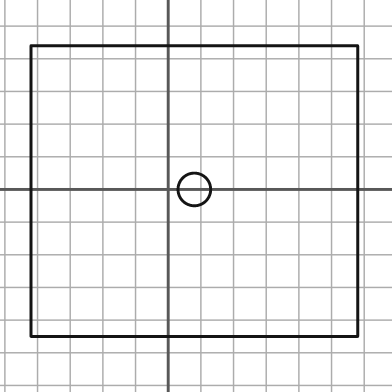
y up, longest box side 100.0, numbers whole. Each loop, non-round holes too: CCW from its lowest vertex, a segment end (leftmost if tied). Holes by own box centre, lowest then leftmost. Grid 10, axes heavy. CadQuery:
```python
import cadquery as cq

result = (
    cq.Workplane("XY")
    .moveTo(-42.0, -45.0)
    .lineTo(58.0, -45.0)
    .lineTo(58.0, 44.0)
    .lineTo(-42.0, 44.0)
    .close()
    .moveTo(8.0, 0.0)
    .circle(5.0)
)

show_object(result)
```